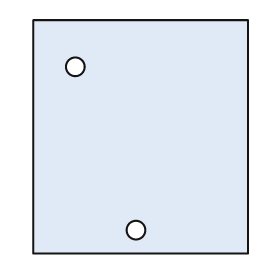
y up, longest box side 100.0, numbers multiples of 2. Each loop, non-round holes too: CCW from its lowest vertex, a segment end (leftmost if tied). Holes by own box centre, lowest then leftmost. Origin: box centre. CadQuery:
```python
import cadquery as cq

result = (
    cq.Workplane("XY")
    .moveTo(-46.0, -50.0)
    .lineTo(46.0, -50.0)
    .lineTo(46.0, 50.0)
    .lineTo(-46.0, 50.0)
    .close()
    .moveTo(-2.0, -40.0)
    .circle(4.0)
    .moveTo(-28.0, 30.0)
    .circle(4.0)
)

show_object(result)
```